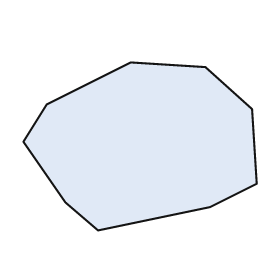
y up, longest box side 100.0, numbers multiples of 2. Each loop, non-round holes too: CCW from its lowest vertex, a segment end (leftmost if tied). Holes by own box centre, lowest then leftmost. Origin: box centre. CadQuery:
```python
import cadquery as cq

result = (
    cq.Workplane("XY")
    .moveTo(-18.0, -36.0)
    .lineTo(30.0, -26.0)
    .lineTo(50.0, -16.0)
    .lineTo(48.0, 16.0)
    .lineTo(28.0, 34.0)
    .lineTo(-4.0, 36.0)
    .lineTo(-40.0, 18.0)
    .lineTo(-50.0, 2.0)
    .lineTo(-32.0, -24.0)
    .close()
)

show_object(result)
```